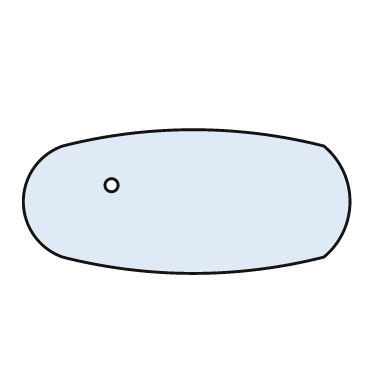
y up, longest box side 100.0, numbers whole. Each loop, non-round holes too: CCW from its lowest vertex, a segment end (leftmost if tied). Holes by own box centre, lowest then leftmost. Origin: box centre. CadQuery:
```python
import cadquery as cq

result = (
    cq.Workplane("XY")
    .moveTo(-38.0, -17.0)
    .threePointArc((2.0, -22.0), (42.0, -17.0))
    .threePointArc((50.0, 0.0), (42.0, 17.0))
    .threePointArc((2.0, 22.0), (-38.0, 17.0))
    .threePointArc((-50.0, 0.0), (-38.0, -17.0))
    .close()
    .moveTo(-23.0, 5.0)
    .circle(2.0)
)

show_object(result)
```